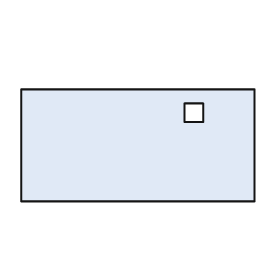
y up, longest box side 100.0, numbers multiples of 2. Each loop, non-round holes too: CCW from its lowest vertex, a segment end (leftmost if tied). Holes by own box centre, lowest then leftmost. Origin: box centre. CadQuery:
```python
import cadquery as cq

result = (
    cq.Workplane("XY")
    .moveTo(-50.0, -24.0)
    .lineTo(50.0, -24.0)
    .lineTo(50.0, 24.0)
    .lineTo(-50.0, 24.0)
    .close()
    .moveTo(20.0, 10.0)
    .lineTo(28.0, 10.0)
    .lineTo(28.0, 18.0)
    .lineTo(20.0, 18.0)
    .close()
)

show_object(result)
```